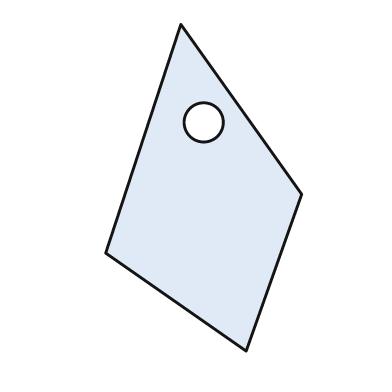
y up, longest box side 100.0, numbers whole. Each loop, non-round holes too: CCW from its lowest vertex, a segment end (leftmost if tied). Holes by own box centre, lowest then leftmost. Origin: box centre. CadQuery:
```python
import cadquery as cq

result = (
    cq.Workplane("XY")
    .moveTo(13.0, -50.0)
    .lineTo(30.0, -2.0)
    .lineTo(-7.0, 50.0)
    .lineTo(-30.0, -20.0)
    .close()
    .moveTo(0.0, 20.0)
    .circle(6.0)
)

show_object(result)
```